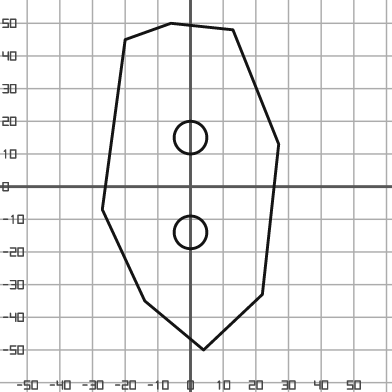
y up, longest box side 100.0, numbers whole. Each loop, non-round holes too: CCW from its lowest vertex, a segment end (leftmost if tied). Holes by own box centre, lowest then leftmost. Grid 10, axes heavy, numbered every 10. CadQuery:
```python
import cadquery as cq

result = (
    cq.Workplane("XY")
    .moveTo(4.0, -50.0)
    .lineTo(22.0, -33.0)
    .lineTo(27.0, 13.0)
    .lineTo(13.0, 48.0)
    .lineTo(-6.0, 50.0)
    .lineTo(-20.0, 45.0)
    .lineTo(-27.0, -7.0)
    .lineTo(-14.0, -35.0)
    .close()
    .moveTo(0.0, -14.0)
    .circle(5.0)
    .moveTo(0.0, 15.0)
    .circle(5.0)
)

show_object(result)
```